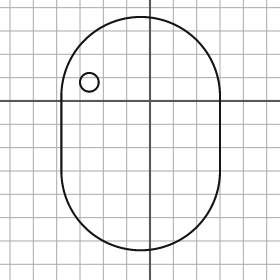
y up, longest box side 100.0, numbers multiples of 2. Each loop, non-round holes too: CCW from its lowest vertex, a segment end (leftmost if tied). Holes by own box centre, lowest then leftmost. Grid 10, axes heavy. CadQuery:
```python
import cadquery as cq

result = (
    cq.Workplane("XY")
    .moveTo(-38.0, -30.0)
    .threePointArc((-4.0, -64.0), (30.0, -30.0))
    .lineTo(30.0, 2.0)
    .threePointArc((-4.0, 36.0), (-38.0, 2.0))
    .close()
    .moveTo(-26.0, 8.0)
    .circle(4.0)
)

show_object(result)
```